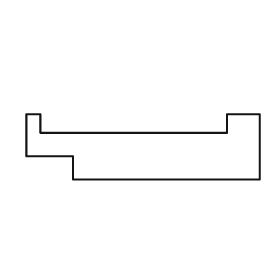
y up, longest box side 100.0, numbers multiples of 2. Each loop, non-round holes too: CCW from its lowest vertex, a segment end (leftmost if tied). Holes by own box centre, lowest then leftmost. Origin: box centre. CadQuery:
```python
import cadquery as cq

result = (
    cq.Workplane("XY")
    .moveTo(-30.0, -14.0)
    .lineTo(50.0, -14.0)
    .lineTo(50.0, 14.0)
    .lineTo(36.0, 14.0)
    .lineTo(36.0, 6.0)
    .lineTo(-44.0, 6.0)
    .lineTo(-44.0, 14.0)
    .lineTo(-50.0, 14.0)
    .lineTo(-50.0, -4.0)
    .lineTo(-30.0, -4.0)
    .close()
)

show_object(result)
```